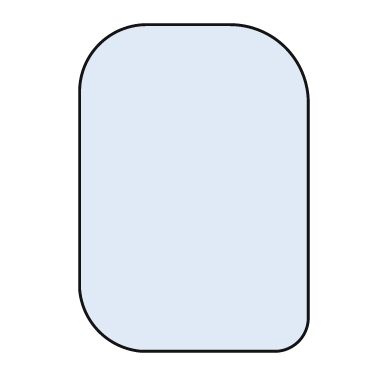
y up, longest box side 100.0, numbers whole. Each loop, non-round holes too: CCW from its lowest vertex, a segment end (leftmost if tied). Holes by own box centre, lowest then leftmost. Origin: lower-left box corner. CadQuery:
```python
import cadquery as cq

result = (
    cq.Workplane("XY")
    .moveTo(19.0, 0.0)
    .lineTo(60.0, 0.0)
    .threePointArc((67.0, 3.0), (70.0, 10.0))
    .lineTo(70.0, 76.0)
    .threePointArc((63.0, 93.0), (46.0, 100.0))
    .lineTo(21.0, 100.0)
    .threePointArc((6.0, 94.0), (0.0, 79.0))
    .lineTo(0.0, 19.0)
    .threePointArc((6.0, 6.0), (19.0, 0.0))
    .close()
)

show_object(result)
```